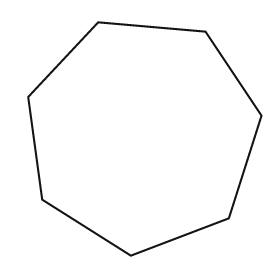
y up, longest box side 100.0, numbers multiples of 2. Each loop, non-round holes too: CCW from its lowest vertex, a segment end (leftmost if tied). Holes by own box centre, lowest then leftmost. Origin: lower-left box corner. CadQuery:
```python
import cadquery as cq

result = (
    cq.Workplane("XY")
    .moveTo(44.0, 0.0)
    .lineTo(86.0, 16.0)
    .lineTo(100.0, 60.0)
    .lineTo(76.0, 96.0)
    .lineTo(30.0, 100.0)
    .lineTo(0.0, 68.0)
    .lineTo(6.0, 24.0)
    .close()
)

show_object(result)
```